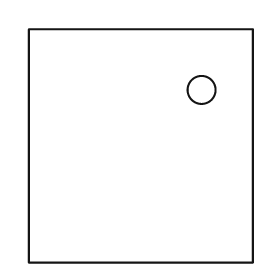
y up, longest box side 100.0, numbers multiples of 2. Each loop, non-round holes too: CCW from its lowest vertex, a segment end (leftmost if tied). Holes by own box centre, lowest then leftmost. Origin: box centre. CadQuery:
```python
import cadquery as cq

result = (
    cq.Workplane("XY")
    .moveTo(-48.0, -50.0)
    .lineTo(48.0, -50.0)
    .lineTo(48.0, 50.0)
    .lineTo(-48.0, 50.0)
    .close()
    .moveTo(26.0, 24.0)
    .circle(6.0)
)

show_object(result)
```